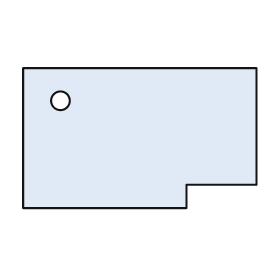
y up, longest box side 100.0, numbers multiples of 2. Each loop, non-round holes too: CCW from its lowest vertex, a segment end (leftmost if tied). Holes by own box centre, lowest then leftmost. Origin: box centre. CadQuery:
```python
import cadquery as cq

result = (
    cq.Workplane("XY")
    .moveTo(-50.0, -30.0)
    .lineTo(20.0, -30.0)
    .lineTo(20.0, -20.0)
    .lineTo(50.0, -20.0)
    .lineTo(50.0, 30.0)
    .lineTo(-50.0, 30.0)
    .close()
    .moveTo(-34.0, 16.0)
    .circle(4.0)
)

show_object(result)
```